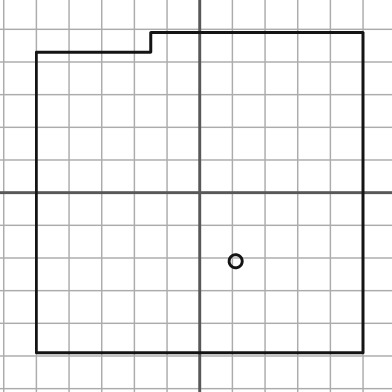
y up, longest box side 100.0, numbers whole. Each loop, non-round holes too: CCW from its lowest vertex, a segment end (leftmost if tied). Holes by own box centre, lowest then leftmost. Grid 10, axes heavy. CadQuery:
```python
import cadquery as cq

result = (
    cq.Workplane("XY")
    .moveTo(-50.0, -49.0)
    .lineTo(50.0, -49.0)
    .lineTo(50.0, 49.0)
    .lineTo(-15.0, 49.0)
    .lineTo(-15.0, 43.0)
    .lineTo(-50.0, 43.0)
    .close()
    .moveTo(11.0, -21.0)
    .circle(2.0)
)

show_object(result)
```